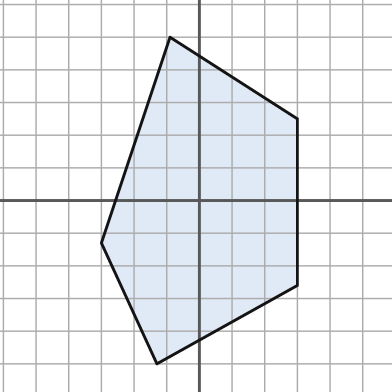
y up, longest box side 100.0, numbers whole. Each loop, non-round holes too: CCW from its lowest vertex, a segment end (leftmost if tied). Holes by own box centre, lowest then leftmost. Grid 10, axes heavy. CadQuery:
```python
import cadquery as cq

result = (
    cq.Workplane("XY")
    .moveTo(-13.0, -50.0)
    .lineTo(30.0, -26.0)
    .lineTo(30.0, 25.0)
    .lineTo(-9.0, 50.0)
    .lineTo(-30.0, -13.0)
    .close()
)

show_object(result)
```